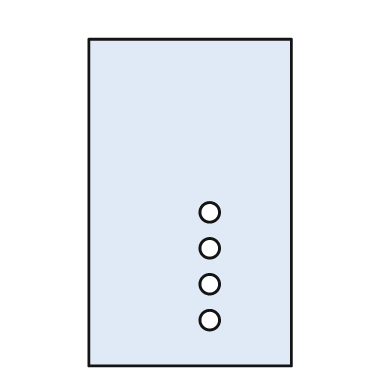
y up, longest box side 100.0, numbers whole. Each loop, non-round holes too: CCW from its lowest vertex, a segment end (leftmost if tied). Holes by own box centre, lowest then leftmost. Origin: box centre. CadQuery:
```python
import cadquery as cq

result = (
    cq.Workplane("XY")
    .moveTo(-31.0, -50.0)
    .lineTo(31.0, -50.0)
    .lineTo(31.0, 50.0)
    .lineTo(-31.0, 50.0)
    .close()
    .moveTo(6.0, -36.0)
    .circle(3.0)
    .moveTo(6.0, -25.0)
    .circle(3.0)
    .moveTo(6.0, -14.0)
    .circle(3.0)
    .moveTo(6.0, -3.0)
    .circle(3.0)
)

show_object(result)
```